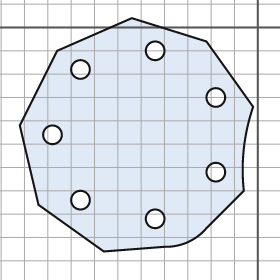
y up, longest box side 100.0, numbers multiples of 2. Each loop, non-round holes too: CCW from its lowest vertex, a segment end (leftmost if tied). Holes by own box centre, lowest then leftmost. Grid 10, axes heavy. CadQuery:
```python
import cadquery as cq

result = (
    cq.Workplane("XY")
    .moveTo(-66.0, -96.0)
    .lineTo(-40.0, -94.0)
    .threePointArc((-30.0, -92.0), (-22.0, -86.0))
    .lineTo(-6.0, -70.0)
    .threePointArc((-6.0, -52.0), (-2.0, -34.0))
    .lineTo(-22.0, -6.0)
    .lineTo(-54.0, 4.0)
    .lineTo(-86.0, -10.0)
    .lineTo(-102.0, -42.0)
    .lineTo(-94.0, -76.0)
    .close()
    .moveTo(-44.0, -82.0)
    .circle(4.0)
    .moveTo(-76.0, -74.0)
    .circle(4.0)
    .moveTo(-18.0, -62.0)
    .circle(4.0)
    .moveTo(-88.0, -46.0)
    .circle(4.0)
    .moveTo(-18.0, -30.0)
    .circle(4.0)
    .moveTo(-76.0, -18.0)
    .circle(4.0)
    .moveTo(-44.0, -10.0)
    .circle(4.0)
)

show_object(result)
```